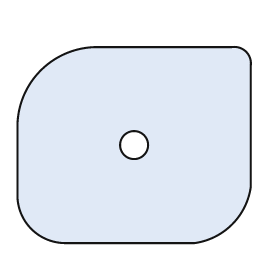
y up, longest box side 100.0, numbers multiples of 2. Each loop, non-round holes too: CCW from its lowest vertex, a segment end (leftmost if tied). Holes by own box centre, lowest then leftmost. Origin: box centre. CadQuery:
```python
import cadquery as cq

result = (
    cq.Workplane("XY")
    .moveTo(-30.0, -42.0)
    .lineTo(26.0, -42.0)
    .threePointArc((42.0, -34.0), (50.0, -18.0))
    .lineTo(50.0, 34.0)
    .threePointArc((48.0, 40.0), (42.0, 42.0))
    .lineTo(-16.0, 42.0)
    .threePointArc((-40.0, 32.0), (-50.0, 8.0))
    .lineTo(-50.0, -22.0)
    .threePointArc((-44.0, -36.0), (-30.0, -42.0))
    .close()
    .moveTo(0.0, 0.0)
    .circle(6.0)
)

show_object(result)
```